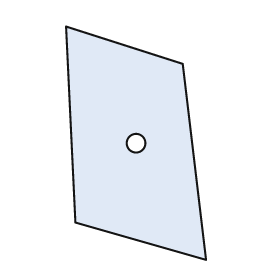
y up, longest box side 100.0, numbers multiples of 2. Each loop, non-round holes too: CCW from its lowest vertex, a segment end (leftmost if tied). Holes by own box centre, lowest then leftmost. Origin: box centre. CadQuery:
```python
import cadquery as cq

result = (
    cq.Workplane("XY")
    .moveTo(30.0, -50.0)
    .lineTo(20.0, 34.0)
    .lineTo(-30.0, 50.0)
    .lineTo(-26.0, -34.0)
    .close()
    .moveTo(0.0, 0.0)
    .circle(4.0)
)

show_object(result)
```